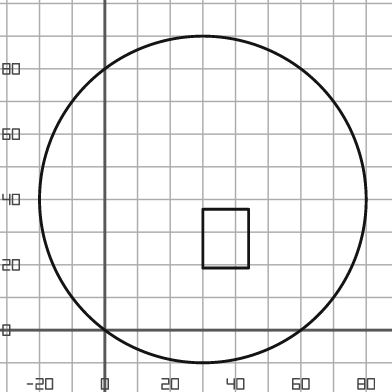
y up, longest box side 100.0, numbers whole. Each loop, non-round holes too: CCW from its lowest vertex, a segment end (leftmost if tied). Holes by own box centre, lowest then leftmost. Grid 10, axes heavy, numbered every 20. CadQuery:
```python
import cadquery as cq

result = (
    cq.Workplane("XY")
    .moveTo(30.0, 40.0)
    .circle(50.0)
    .moveTo(30.0, 19.0)
    .lineTo(44.0, 19.0)
    .lineTo(44.0, 37.0)
    .lineTo(30.0, 37.0)
    .close()
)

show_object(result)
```